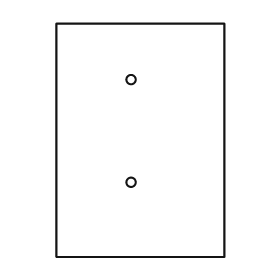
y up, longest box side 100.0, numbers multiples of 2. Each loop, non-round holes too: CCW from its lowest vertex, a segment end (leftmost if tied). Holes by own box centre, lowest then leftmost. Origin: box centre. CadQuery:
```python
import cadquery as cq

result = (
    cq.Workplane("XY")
    .moveTo(-36.0, -50.0)
    .lineTo(36.0, -50.0)
    .lineTo(36.0, 50.0)
    .lineTo(-36.0, 50.0)
    .close()
    .moveTo(-4.0, -18.0)
    .circle(2.0)
    .moveTo(-4.0, 26.0)
    .circle(2.0)
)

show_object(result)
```